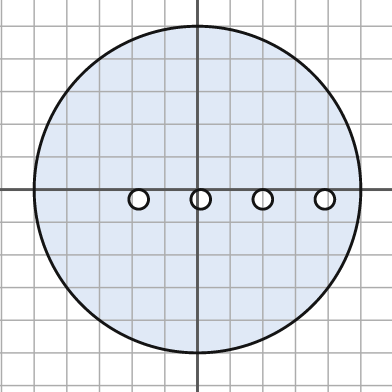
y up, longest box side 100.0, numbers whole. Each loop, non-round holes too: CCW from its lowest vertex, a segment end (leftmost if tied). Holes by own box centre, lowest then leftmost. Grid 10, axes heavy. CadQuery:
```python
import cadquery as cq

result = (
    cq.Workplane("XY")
    .moveTo(0.0, 0.0)
    .circle(50.0)
    .moveTo(-18.0, -3.0)
    .circle(3.0)
    .moveTo(1.0, -3.0)
    .circle(3.0)
    .moveTo(20.0, -3.0)
    .circle(3.0)
    .moveTo(39.0, -3.0)
    .circle(3.0)
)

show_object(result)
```